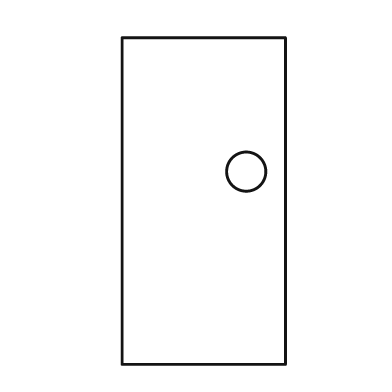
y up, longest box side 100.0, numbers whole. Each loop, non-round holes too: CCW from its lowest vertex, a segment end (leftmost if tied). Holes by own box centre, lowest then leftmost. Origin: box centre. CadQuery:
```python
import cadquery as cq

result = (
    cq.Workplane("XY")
    .moveTo(-25.0, -50.0)
    .lineTo(25.0, -50.0)
    .lineTo(25.0, 50.0)
    .lineTo(-25.0, 50.0)
    .close()
    .moveTo(13.0, 9.0)
    .circle(6.0)
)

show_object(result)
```